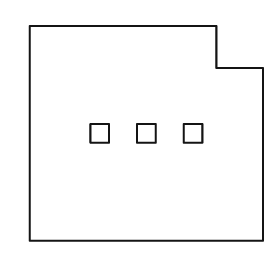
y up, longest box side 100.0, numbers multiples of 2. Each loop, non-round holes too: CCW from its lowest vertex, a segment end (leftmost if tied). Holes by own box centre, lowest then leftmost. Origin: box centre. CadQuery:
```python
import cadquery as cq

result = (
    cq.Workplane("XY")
    .moveTo(-50.0, -46.0)
    .lineTo(50.0, -46.0)
    .lineTo(50.0, 28.0)
    .lineTo(30.0, 28.0)
    .lineTo(30.0, 46.0)
    .lineTo(-50.0, 46.0)
    .close()
    .moveTo(-24.0, -4.0)
    .lineTo(-16.0, -4.0)
    .lineTo(-16.0, 4.0)
    .lineTo(-24.0, 4.0)
    .close()
    .moveTo(-4.0, -4.0)
    .lineTo(4.0, -4.0)
    .lineTo(4.0, 4.0)
    .lineTo(-4.0, 4.0)
    .close()
    .moveTo(16.0, -4.0)
    .lineTo(24.0, -4.0)
    .lineTo(24.0, 4.0)
    .lineTo(16.0, 4.0)
    .close()
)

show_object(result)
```